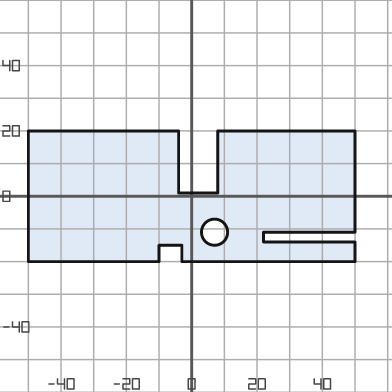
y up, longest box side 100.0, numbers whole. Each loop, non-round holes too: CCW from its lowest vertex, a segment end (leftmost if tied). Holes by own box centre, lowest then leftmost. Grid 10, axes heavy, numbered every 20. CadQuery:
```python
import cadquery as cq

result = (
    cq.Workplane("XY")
    .moveTo(-50.0, -20.0)
    .lineTo(-10.0, -20.0)
    .lineTo(-10.0, -15.0)
    .lineTo(-3.0, -15.0)
    .lineTo(-3.0, -20.0)
    .lineTo(50.0, -20.0)
    .lineTo(50.0, -14.0)
    .lineTo(22.0, -14.0)
    .lineTo(22.0, -11.0)
    .lineTo(50.0, -11.0)
    .lineTo(50.0, 20.0)
    .lineTo(8.0, 20.0)
    .lineTo(8.0, 1.0)
    .lineTo(-4.0, 1.0)
    .lineTo(-4.0, 20.0)
    .lineTo(-50.0, 20.0)
    .close()
    .moveTo(7.0, -11.0)
    .circle(4.0)
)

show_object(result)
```